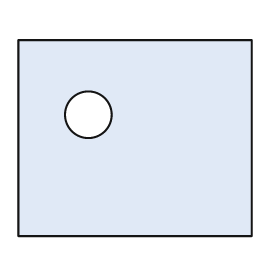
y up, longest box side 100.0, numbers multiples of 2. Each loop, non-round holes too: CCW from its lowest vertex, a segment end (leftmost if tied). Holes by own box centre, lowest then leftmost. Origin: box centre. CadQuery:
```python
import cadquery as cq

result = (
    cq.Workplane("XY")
    .moveTo(-50.0, -42.0)
    .lineTo(50.0, -42.0)
    .lineTo(50.0, 42.0)
    .lineTo(-50.0, 42.0)
    .close()
    .moveTo(-20.0, 10.0)
    .circle(10.0)
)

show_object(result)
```